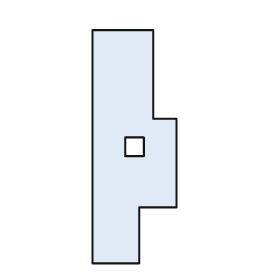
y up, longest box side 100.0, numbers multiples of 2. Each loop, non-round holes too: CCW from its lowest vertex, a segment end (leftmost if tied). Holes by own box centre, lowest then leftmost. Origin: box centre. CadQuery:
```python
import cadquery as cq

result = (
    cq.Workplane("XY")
    .moveTo(-18.0, -50.0)
    .lineTo(2.0, -50.0)
    .lineTo(2.0, -26.0)
    .lineTo(18.0, -26.0)
    .lineTo(18.0, 12.0)
    .lineTo(8.0, 12.0)
    .lineTo(8.0, 50.0)
    .lineTo(-18.0, 50.0)
    .close()
    .moveTo(-4.0, -4.0)
    .lineTo(4.0, -4.0)
    .lineTo(4.0, 4.0)
    .lineTo(-4.0, 4.0)
    .close()
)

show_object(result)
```